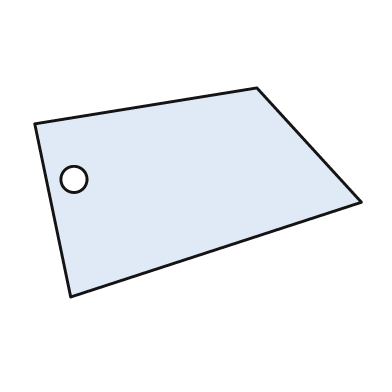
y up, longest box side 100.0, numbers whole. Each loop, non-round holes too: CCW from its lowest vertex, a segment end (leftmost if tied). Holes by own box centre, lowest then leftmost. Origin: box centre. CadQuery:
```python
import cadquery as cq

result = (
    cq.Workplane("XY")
    .moveTo(-39.0, -32.0)
    .lineTo(50.0, -3.0)
    .lineTo(18.0, 32.0)
    .lineTo(-50.0, 21.0)
    .close()
    .moveTo(-38.0, 4.0)
    .circle(4.0)
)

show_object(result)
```